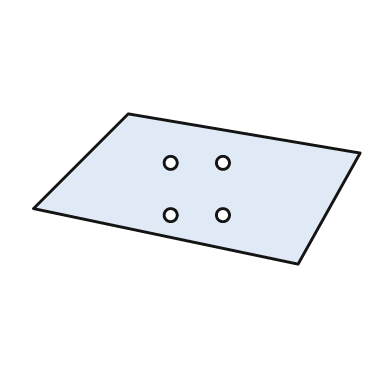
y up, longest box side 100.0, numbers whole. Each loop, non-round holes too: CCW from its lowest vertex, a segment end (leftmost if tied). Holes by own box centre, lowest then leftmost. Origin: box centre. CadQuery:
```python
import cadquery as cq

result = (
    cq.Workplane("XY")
    .moveTo(31.0, -23.0)
    .lineTo(50.0, 11.0)
    .lineTo(-21.0, 23.0)
    .lineTo(-50.0, -6.0)
    .close()
    .moveTo(-8.0, -8.0)
    .circle(2.0)
    .moveTo(8.0, -8.0)
    .circle(2.0)
    .moveTo(-8.0, 8.0)
    .circle(2.0)
    .moveTo(8.0, 8.0)
    .circle(2.0)
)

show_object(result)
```